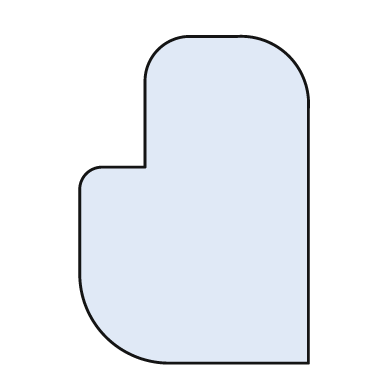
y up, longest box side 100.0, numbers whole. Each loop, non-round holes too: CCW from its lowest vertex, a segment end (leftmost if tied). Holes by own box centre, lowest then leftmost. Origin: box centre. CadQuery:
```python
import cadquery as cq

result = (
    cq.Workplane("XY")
    .moveTo(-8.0, -50.0)
    .lineTo(35.0, -50.0)
    .lineTo(35.0, 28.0)
    .threePointArc((29.0, 44.0), (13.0, 50.0))
    .lineTo(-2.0, 50.0)
    .threePointArc((-11.0, 46.0), (-15.0, 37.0))
    .lineTo(-15.0, 10.0)
    .lineTo(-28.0, 10.0)
    .threePointArc((-33.0, 8.0), (-35.0, 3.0))
    .lineTo(-35.0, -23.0)
    .threePointArc((-27.0, -42.0), (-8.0, -50.0))
    .close()
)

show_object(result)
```